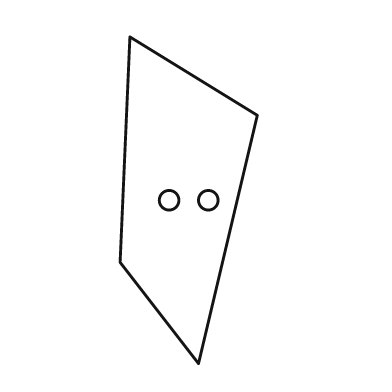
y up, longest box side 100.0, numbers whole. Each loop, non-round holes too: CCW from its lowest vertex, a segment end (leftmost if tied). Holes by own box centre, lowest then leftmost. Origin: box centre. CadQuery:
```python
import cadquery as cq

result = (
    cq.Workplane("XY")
    .moveTo(3.0, -50.0)
    .lineTo(21.0, 26.0)
    .lineTo(-18.0, 50.0)
    .lineTo(-21.0, -19.0)
    .close()
    .moveTo(-6.0, 0.0)
    .circle(3.0)
    .moveTo(6.0, 0.0)
    .circle(3.0)
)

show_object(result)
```